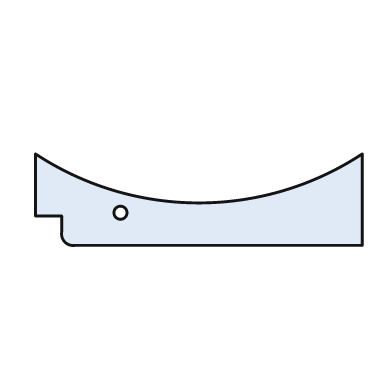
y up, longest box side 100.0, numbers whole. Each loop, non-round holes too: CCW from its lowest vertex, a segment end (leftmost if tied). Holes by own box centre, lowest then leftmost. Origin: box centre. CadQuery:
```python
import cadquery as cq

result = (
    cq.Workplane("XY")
    .moveTo(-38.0, -14.0)
    .lineTo(50.0, -14.0)
    .lineTo(50.0, 14.0)
    .threePointArc((0.0, -1.0), (-50.0, 14.0))
    .lineTo(-50.0, -5.0)
    .lineTo(-42.0, -5.0)
    .lineTo(-42.0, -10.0)
    .threePointArc((-41.0, -13.0), (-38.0, -14.0))
    .close()
    .moveTo(-24.0, -4.0)
    .circle(2.0)
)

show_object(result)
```